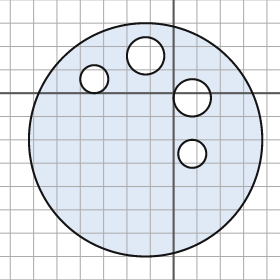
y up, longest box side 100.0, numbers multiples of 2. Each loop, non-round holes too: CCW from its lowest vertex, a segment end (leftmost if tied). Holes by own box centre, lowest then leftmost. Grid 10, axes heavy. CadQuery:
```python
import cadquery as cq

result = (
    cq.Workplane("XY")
    .moveTo(-12.0, -20.0)
    .circle(50.0)
    .moveTo(8.0, -26.0)
    .circle(6.0)
    .moveTo(8.0, -2.0)
    .circle(8.0)
    .moveTo(-34.0, 6.0)
    .circle(6.0)
    .moveTo(-12.0, 16.0)
    .circle(8.0)
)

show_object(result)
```